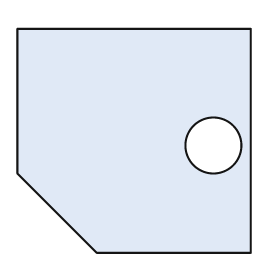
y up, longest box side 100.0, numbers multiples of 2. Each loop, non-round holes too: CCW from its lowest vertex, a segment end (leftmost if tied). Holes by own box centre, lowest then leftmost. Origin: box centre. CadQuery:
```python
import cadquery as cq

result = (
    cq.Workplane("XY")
    .moveTo(-16.0, -48.0)
    .lineTo(50.0, -48.0)
    .lineTo(50.0, 48.0)
    .lineTo(-50.0, 48.0)
    .lineTo(-50.0, -14.0)
    .close()
    .moveTo(34.0, -2.0)
    .circle(12.0)
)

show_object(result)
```